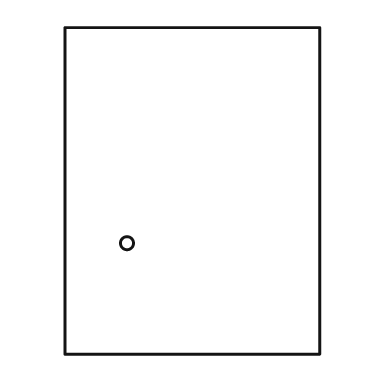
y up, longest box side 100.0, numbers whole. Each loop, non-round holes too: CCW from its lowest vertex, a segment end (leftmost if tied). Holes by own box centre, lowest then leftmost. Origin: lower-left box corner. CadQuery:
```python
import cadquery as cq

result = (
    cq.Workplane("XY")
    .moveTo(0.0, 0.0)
    .lineTo(78.0, 0.0)
    .lineTo(78.0, 100.0)
    .lineTo(0.0, 100.0)
    .close()
    .moveTo(19.0, 34.0)
    .circle(2.0)
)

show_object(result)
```